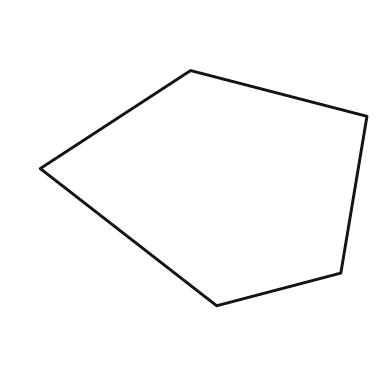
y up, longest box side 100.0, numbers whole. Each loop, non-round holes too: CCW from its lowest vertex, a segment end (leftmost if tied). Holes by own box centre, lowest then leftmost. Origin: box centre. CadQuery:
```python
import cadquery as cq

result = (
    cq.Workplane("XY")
    .moveTo(4.0, -36.0)
    .lineTo(42.0, -26.0)
    .lineTo(50.0, 22.0)
    .lineTo(-4.0, 36.0)
    .lineTo(-50.0, 6.0)
    .close()
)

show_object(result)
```